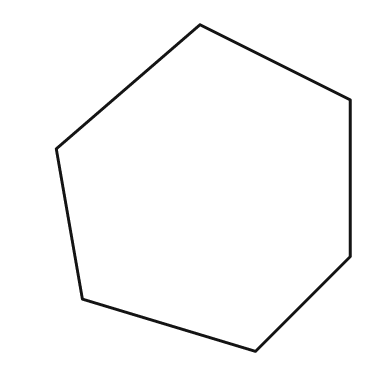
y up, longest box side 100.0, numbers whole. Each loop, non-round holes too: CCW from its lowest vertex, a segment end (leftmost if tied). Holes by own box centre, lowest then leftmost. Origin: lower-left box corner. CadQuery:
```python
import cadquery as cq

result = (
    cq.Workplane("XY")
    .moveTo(61.0, 0.0)
    .lineTo(90.0, 29.0)
    .lineTo(90.0, 77.0)
    .lineTo(44.0, 100.0)
    .lineTo(0.0, 62.0)
    .lineTo(8.0, 16.0)
    .close()
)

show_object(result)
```